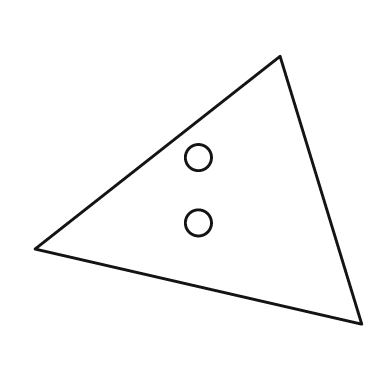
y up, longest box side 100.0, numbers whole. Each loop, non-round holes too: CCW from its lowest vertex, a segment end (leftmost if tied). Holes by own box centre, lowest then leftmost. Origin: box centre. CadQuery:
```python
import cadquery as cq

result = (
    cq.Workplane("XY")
    .moveTo(50.0, -41.0)
    .lineTo(25.0, 41.0)
    .lineTo(-50.0, -18.0)
    .close()
    .moveTo(0.0, -10.0)
    .circle(4.0)
    .moveTo(0.0, 10.0)
    .circle(4.0)
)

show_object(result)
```